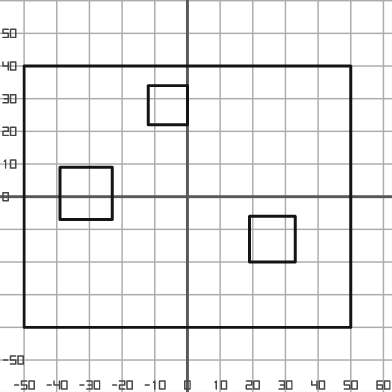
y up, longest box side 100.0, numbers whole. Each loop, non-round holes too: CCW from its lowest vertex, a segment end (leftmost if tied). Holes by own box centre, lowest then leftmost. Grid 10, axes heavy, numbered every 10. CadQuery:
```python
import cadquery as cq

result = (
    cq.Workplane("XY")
    .moveTo(-50.0, -40.0)
    .lineTo(50.0, -40.0)
    .lineTo(50.0, 40.0)
    .lineTo(-50.0, 40.0)
    .close()
    .moveTo(19.0, -20.0)
    .lineTo(33.0, -20.0)
    .lineTo(33.0, -6.0)
    .lineTo(19.0, -6.0)
    .close()
    .moveTo(-39.0, -7.0)
    .lineTo(-23.0, -7.0)
    .lineTo(-23.0, 9.0)
    .lineTo(-39.0, 9.0)
    .close()
    .moveTo(-12.0, 22.0)
    .lineTo(0.0, 22.0)
    .lineTo(0.0, 34.0)
    .lineTo(-12.0, 34.0)
    .close()
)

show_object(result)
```